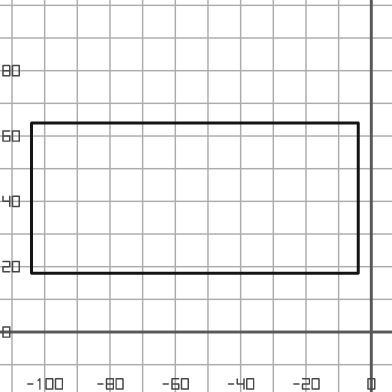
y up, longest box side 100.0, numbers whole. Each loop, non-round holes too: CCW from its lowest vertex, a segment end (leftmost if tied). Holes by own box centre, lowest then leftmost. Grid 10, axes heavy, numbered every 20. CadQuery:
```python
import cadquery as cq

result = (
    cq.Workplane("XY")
    .moveTo(-104.0, 18.0)
    .lineTo(-4.0, 18.0)
    .lineTo(-4.0, 64.0)
    .lineTo(-104.0, 64.0)
    .close()
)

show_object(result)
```